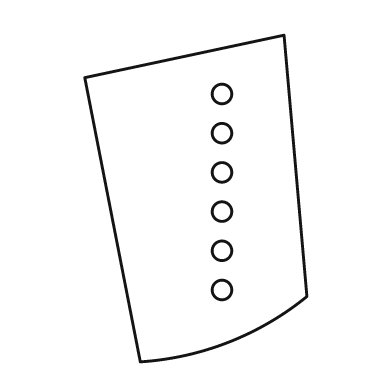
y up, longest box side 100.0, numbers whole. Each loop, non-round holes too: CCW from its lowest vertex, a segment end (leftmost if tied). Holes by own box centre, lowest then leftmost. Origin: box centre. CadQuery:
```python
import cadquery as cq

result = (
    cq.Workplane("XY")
    .moveTo(-17.0, -50.0)
    .threePointArc((10.0, -44.0), (34.0, -30.0))
    .lineTo(27.0, 50.0)
    .lineTo(-34.0, 37.0)
    .close()
    .moveTo(8.0, -28.0)
    .circle(3.0)
    .moveTo(8.0, -16.0)
    .circle(3.0)
    .moveTo(8.0, -4.0)
    .circle(3.0)
    .moveTo(8.0, 8.0)
    .circle(3.0)
    .moveTo(8.0, 20.0)
    .circle(3.0)
    .moveTo(8.0, 32.0)
    .circle(3.0)
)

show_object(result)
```